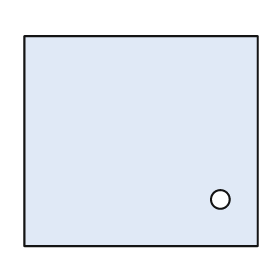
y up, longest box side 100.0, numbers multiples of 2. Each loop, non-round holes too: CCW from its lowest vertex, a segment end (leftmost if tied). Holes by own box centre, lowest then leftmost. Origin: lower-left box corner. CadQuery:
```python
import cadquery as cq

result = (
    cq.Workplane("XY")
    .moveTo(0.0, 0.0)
    .lineTo(100.0, 0.0)
    .lineTo(100.0, 90.0)
    .lineTo(0.0, 90.0)
    .close()
    .moveTo(84.0, 20.0)
    .circle(4.0)
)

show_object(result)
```